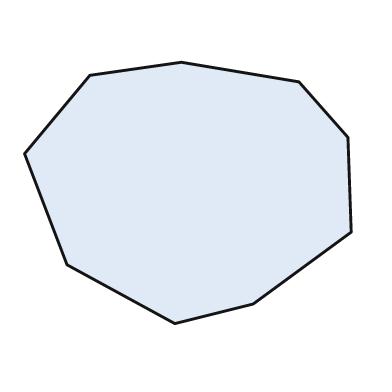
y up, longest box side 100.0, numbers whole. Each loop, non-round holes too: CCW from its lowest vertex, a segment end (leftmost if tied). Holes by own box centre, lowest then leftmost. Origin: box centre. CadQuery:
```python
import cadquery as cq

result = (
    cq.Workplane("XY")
    .moveTo(-4.0, -40.0)
    .lineTo(20.0, -34.0)
    .lineTo(50.0, -12.0)
    .lineTo(49.0, 17.0)
    .lineTo(34.0, 34.0)
    .lineTo(-2.0, 40.0)
    .lineTo(-30.0, 36.0)
    .lineTo(-50.0, 12.0)
    .lineTo(-37.0, -22.0)
    .close()
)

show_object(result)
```